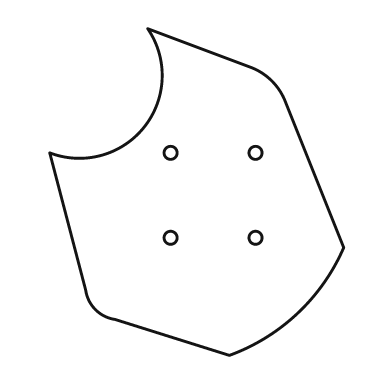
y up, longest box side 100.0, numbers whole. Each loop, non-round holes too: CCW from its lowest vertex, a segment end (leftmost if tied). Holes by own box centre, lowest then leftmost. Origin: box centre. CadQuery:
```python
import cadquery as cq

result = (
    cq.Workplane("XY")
    .moveTo(10.0, -50.0)
    .threePointArc((31.0, -37.0), (45.0, -17.0))
    .lineTo(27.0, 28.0)
    .threePointArc((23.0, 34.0), (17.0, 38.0))
    .lineTo(-15.0, 50.0)
    .threePointArc((-16.0, 20.0), (-45.0, 12.0))
    .lineTo(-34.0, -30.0)
    .threePointArc((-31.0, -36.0), (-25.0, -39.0))
    .close()
    .moveTo(-8.0, -14.0)
    .circle(2.0)
    .moveTo(18.0, -14.0)
    .circle(2.0)
    .moveTo(-8.0, 12.0)
    .circle(2.0)
    .moveTo(18.0, 12.0)
    .circle(2.0)
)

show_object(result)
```